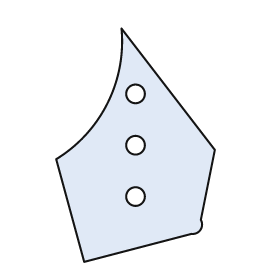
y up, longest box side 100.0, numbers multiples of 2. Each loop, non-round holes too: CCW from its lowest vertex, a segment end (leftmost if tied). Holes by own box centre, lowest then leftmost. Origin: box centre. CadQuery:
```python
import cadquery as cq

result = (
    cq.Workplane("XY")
    .moveTo(-22.0, -50.0)
    .lineTo(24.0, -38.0)
    .threePointArc((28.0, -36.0), (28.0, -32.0))
    .lineTo(34.0, -2.0)
    .lineTo(-6.0, 50.0)
    .threePointArc((-12.0, 18.0), (-34.0, -6.0))
    .close()
    .moveTo(0.0, -22.0)
    .circle(4.0)
    .moveTo(0.0, 0.0)
    .circle(4.0)
    .moveTo(0.0, 22.0)
    .circle(4.0)
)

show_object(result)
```